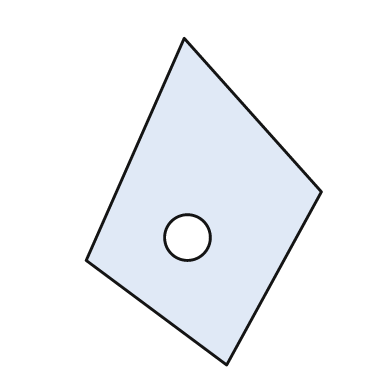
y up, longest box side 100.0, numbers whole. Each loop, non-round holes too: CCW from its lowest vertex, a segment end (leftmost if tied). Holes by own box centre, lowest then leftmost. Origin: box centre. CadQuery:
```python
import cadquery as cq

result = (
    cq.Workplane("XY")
    .moveTo(7.0, -50.0)
    .lineTo(36.0, 3.0)
    .lineTo(-6.0, 50.0)
    .lineTo(-36.0, -18.0)
    .close()
    .moveTo(-5.0, -11.0)
    .circle(7.0)
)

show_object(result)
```